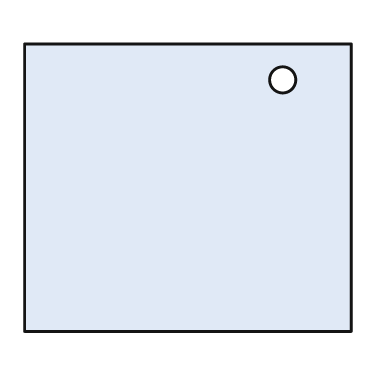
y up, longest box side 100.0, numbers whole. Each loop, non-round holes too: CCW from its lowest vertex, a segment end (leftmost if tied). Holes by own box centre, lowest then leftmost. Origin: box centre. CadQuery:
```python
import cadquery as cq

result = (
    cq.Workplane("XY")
    .moveTo(-50.0, -44.0)
    .lineTo(50.0, -44.0)
    .lineTo(50.0, 44.0)
    .lineTo(-50.0, 44.0)
    .close()
    .moveTo(29.0, 33.0)
    .circle(4.0)
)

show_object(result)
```